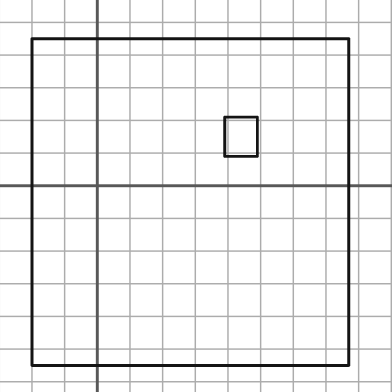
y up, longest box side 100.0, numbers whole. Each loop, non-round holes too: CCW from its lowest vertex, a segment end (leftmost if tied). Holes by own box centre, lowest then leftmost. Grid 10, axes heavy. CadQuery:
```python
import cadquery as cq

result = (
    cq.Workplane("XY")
    .moveTo(-20.0, -55.0)
    .lineTo(77.0, -55.0)
    .lineTo(77.0, 45.0)
    .lineTo(-20.0, 45.0)
    .close()
    .moveTo(39.0, 9.0)
    .lineTo(49.0, 9.0)
    .lineTo(49.0, 21.0)
    .lineTo(39.0, 21.0)
    .close()
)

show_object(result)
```